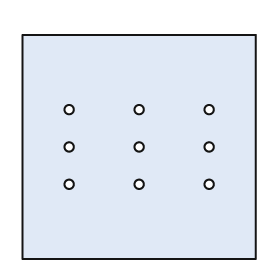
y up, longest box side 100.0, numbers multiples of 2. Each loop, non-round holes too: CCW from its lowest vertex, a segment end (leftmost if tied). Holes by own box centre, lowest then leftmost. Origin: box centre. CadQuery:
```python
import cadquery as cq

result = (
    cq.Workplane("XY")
    .moveTo(-50.0, -48.0)
    .lineTo(50.0, -48.0)
    .lineTo(50.0, 48.0)
    .lineTo(-50.0, 48.0)
    .close()
    .moveTo(-30.0, -16.0)
    .circle(2.0)
    .moveTo(0.0, -16.0)
    .circle(2.0)
    .moveTo(30.0, -16.0)
    .circle(2.0)
    .moveTo(-30.0, 0.0)
    .circle(2.0)
    .moveTo(0.0, 0.0)
    .circle(2.0)
    .moveTo(30.0, 0.0)
    .circle(2.0)
    .moveTo(-30.0, 16.0)
    .circle(2.0)
    .moveTo(0.0, 16.0)
    .circle(2.0)
    .moveTo(30.0, 16.0)
    .circle(2.0)
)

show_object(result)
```